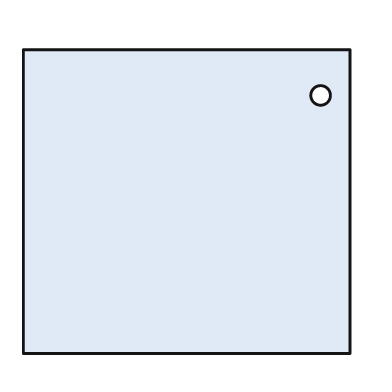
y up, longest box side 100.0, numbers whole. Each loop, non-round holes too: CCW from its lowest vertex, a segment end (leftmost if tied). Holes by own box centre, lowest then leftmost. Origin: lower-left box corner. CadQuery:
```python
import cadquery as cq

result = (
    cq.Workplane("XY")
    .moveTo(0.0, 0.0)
    .lineTo(100.0, 0.0)
    .lineTo(100.0, 93.0)
    .lineTo(0.0, 93.0)
    .close()
    .moveTo(91.0, 79.0)
    .circle(3.0)
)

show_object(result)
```